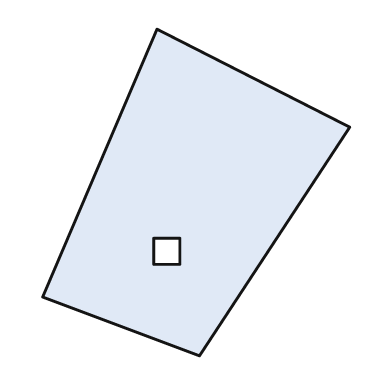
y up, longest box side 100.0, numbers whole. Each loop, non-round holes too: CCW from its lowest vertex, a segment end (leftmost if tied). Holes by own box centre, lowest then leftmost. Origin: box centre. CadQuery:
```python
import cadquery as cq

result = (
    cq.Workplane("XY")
    .moveTo(1.0, -50.0)
    .lineTo(47.0, 20.0)
    .lineTo(-12.0, 50.0)
    .lineTo(-47.0, -32.0)
    .close()
    .moveTo(-13.0, -22.0)
    .lineTo(-5.0, -22.0)
    .lineTo(-5.0, -14.0)
    .lineTo(-13.0, -14.0)
    .close()
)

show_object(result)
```